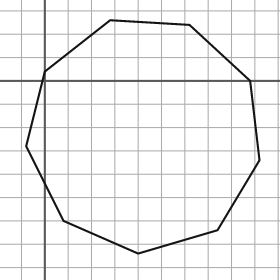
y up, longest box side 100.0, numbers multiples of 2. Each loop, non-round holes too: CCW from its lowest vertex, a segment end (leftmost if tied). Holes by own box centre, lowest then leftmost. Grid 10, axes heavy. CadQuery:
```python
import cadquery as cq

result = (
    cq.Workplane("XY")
    .moveTo(40.0, -74.0)
    .lineTo(74.0, -64.0)
    .lineTo(92.0, -34.0)
    .lineTo(88.0, 0.0)
    .lineTo(62.0, 24.0)
    .lineTo(28.0, 26.0)
    .lineTo(0.0, 4.0)
    .lineTo(-8.0, -28.0)
    .lineTo(8.0, -60.0)
    .close()
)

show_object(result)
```